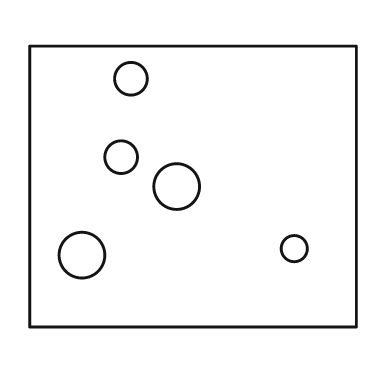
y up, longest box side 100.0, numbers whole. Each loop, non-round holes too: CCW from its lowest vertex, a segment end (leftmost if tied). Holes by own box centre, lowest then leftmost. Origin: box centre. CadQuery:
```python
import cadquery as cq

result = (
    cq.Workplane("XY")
    .moveTo(-50.0, -43.0)
    .lineTo(50.0, -43.0)
    .lineTo(50.0, 43.0)
    .lineTo(-50.0, 43.0)
    .close()
    .moveTo(-34.0, -21.0)
    .circle(7.0)
    .moveTo(31.0, -19.0)
    .circle(4.0)
    .moveTo(-5.0, 0.0)
    .circle(7.0)
    .moveTo(-22.0, 9.0)
    .circle(5.0)
    .moveTo(-19.0, 33.0)
    .circle(5.0)
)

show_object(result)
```